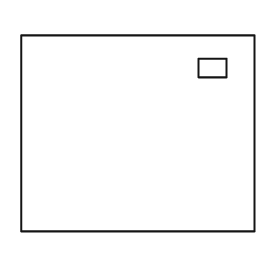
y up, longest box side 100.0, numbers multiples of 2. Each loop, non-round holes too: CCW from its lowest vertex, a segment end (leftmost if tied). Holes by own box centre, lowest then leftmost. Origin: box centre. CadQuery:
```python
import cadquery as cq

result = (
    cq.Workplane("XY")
    .moveTo(-50.0, -42.0)
    .lineTo(50.0, -42.0)
    .lineTo(50.0, 42.0)
    .lineTo(-50.0, 42.0)
    .close()
    .moveTo(26.0, 24.0)
    .lineTo(38.0, 24.0)
    .lineTo(38.0, 32.0)
    .lineTo(26.0, 32.0)
    .close()
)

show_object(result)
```